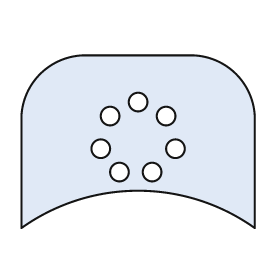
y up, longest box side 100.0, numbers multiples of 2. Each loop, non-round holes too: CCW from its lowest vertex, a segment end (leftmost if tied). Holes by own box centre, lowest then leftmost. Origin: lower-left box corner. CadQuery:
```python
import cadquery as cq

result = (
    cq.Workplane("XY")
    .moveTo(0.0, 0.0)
    .threePointArc((50.0, 16.0), (100.0, 0.0))
    .lineTo(100.0, 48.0)
    .threePointArc((92.0, 66.0), (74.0, 74.0))
    .lineTo(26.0, 74.0)
    .threePointArc((8.0, 66.0), (0.0, 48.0))
    .close()
    .moveTo(42.0, 24.0)
    .circle(4.0)
    .moveTo(56.0, 24.0)
    .circle(4.0)
    .moveTo(34.0, 34.0)
    .circle(4.0)
    .moveTo(66.0, 34.0)
    .circle(4.0)
    .moveTo(38.0, 48.0)
    .circle(4.0)
    .moveTo(62.0, 48.0)
    .circle(4.0)
    .moveTo(50.0, 54.0)
    .circle(4.0)
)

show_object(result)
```